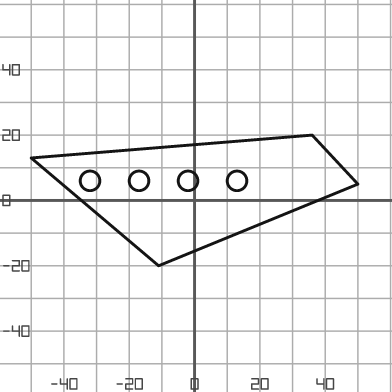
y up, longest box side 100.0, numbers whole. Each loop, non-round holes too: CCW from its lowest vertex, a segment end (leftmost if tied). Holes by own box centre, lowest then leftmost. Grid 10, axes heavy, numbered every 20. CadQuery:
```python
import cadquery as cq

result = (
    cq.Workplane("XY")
    .moveTo(-11.0, -20.0)
    .lineTo(50.0, 5.0)
    .lineTo(36.0, 20.0)
    .lineTo(-50.0, 13.0)
    .close()
    .moveTo(-32.0, 6.0)
    .circle(3.0)
    .moveTo(-17.0, 6.0)
    .circle(3.0)
    .moveTo(-2.0, 6.0)
    .circle(3.0)
    .moveTo(13.0, 6.0)
    .circle(3.0)
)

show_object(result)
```